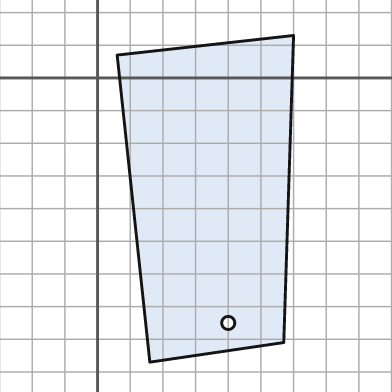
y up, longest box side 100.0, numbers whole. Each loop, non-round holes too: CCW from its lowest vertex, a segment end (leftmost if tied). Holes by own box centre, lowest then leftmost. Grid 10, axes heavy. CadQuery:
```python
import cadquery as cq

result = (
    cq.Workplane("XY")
    .moveTo(16.0, -87.0)
    .lineTo(57.0, -81.0)
    .lineTo(60.0, 13.0)
    .lineTo(6.0, 7.0)
    .close()
    .moveTo(40.0, -75.0)
    .circle(2.0)
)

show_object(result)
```